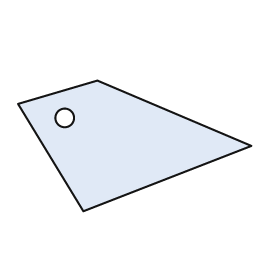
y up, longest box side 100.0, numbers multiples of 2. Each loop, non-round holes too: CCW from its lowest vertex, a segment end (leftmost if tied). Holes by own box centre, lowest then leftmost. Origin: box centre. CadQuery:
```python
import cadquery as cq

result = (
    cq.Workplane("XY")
    .moveTo(-22.0, -28.0)
    .lineTo(50.0, 0.0)
    .lineTo(-16.0, 28.0)
    .lineTo(-50.0, 18.0)
    .close()
    .moveTo(-30.0, 12.0)
    .circle(4.0)
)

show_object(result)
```